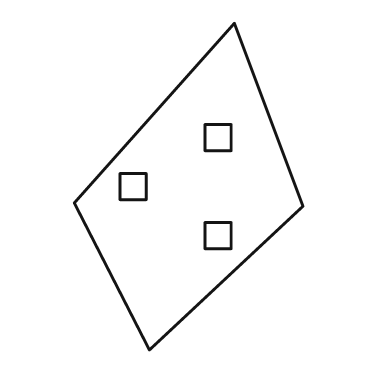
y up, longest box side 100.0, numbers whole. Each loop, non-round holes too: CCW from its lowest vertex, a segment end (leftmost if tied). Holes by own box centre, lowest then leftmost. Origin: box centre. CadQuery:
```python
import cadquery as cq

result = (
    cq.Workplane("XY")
    .moveTo(-12.0, -50.0)
    .lineTo(35.0, -6.0)
    .lineTo(14.0, 50.0)
    .lineTo(-35.0, -5.0)
    .close()
    .moveTo(5.0, -19.0)
    .lineTo(13.0, -19.0)
    .lineTo(13.0, -11.0)
    .lineTo(5.0, -11.0)
    .close()
    .moveTo(-21.0, -4.0)
    .lineTo(-13.0, -4.0)
    .lineTo(-13.0, 4.0)
    .lineTo(-21.0, 4.0)
    .close()
    .moveTo(5.0, 11.0)
    .lineTo(13.0, 11.0)
    .lineTo(13.0, 19.0)
    .lineTo(5.0, 19.0)
    .close()
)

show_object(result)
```